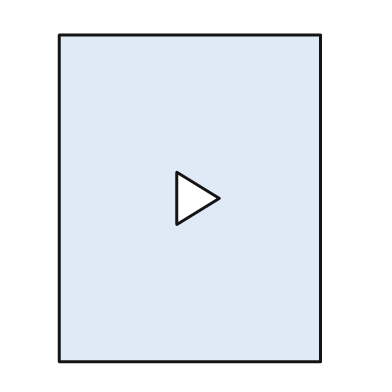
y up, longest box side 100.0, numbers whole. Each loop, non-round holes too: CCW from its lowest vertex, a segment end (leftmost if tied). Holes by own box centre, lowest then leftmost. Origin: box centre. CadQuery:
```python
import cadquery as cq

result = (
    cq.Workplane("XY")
    .moveTo(-40.0, -50.0)
    .lineTo(40.0, -50.0)
    .lineTo(40.0, 50.0)
    .lineTo(-40.0, 50.0)
    .close()
    .moveTo(-4.0, -8.0)
    .lineTo(9.0, 0.0)
    .lineTo(-4.0, 8.0)
    .close()
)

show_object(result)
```